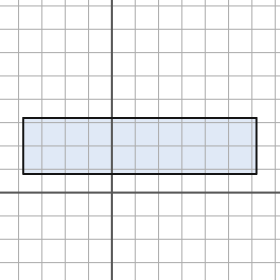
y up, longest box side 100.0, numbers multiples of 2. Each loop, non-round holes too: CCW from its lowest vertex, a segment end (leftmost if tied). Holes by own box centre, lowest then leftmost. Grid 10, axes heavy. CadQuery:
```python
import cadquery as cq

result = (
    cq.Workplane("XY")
    .moveTo(-38.0, 8.0)
    .lineTo(62.0, 8.0)
    .lineTo(62.0, 32.0)
    .lineTo(-38.0, 32.0)
    .close()
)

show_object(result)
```